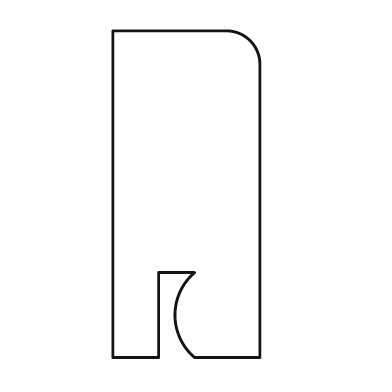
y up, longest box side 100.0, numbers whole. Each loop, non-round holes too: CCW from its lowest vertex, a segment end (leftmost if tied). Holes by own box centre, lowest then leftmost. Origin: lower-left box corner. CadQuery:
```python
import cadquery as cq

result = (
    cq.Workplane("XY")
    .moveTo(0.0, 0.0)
    .lineTo(14.0, 0.0)
    .lineTo(14.0, 26.0)
    .lineTo(25.0, 26.0)
    .threePointArc((19.0, 13.0), (25.0, 0.0))
    .lineTo(45.0, 0.0)
    .lineTo(45.0, 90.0)
    .threePointArc((42.0, 97.0), (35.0, 100.0))
    .lineTo(0.0, 100.0)
    .close()
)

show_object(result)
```